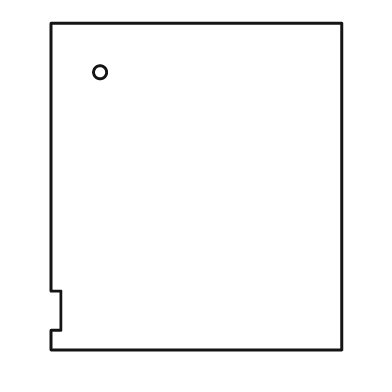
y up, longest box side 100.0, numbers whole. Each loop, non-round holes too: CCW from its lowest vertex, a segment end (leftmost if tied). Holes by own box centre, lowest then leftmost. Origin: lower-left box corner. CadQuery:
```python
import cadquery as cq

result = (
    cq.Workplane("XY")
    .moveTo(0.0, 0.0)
    .lineTo(89.0, 0.0)
    .lineTo(89.0, 100.0)
    .lineTo(0.0, 100.0)
    .lineTo(0.0, 18.0)
    .lineTo(3.0, 18.0)
    .lineTo(3.0, 6.0)
    .lineTo(0.0, 6.0)
    .close()
    .moveTo(15.0, 85.0)
    .circle(2.0)
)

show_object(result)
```